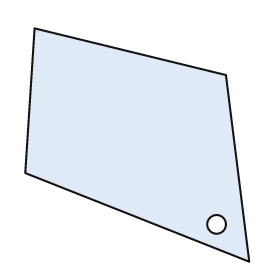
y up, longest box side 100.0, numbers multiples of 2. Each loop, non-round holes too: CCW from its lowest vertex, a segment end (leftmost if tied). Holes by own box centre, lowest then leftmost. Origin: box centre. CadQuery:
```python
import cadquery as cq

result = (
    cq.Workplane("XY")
    .moveTo(48.0, -50.0)
    .lineTo(38.0, 30.0)
    .lineTo(-44.0, 50.0)
    .lineTo(-48.0, -12.0)
    .close()
    .moveTo(34.0, -34.0)
    .circle(4.0)
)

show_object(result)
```